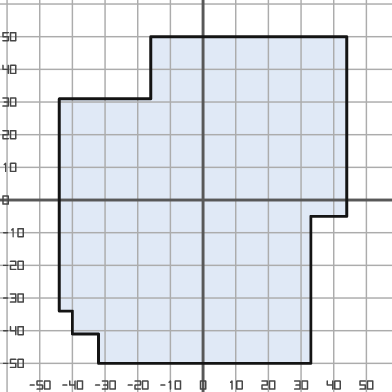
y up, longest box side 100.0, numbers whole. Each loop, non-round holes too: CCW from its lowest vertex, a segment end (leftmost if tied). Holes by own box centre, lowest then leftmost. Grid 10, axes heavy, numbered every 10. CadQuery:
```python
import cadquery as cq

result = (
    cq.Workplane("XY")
    .moveTo(-32.0, -50.0)
    .lineTo(33.0, -50.0)
    .lineTo(33.0, -5.0)
    .lineTo(44.0, -5.0)
    .lineTo(44.0, 50.0)
    .lineTo(-16.0, 50.0)
    .lineTo(-16.0, 31.0)
    .lineTo(-44.0, 31.0)
    .lineTo(-44.0, -34.0)
    .lineTo(-40.0, -34.0)
    .lineTo(-40.0, -41.0)
    .lineTo(-32.0, -41.0)
    .close()
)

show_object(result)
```